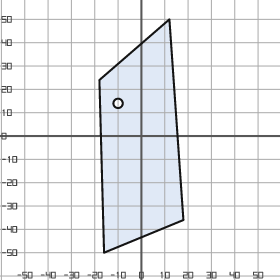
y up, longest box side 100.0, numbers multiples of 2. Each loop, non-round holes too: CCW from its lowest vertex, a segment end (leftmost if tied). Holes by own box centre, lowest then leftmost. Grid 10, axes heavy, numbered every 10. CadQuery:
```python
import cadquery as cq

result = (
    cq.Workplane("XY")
    .moveTo(-16.0, -50.0)
    .lineTo(18.0, -36.0)
    .lineTo(12.0, 50.0)
    .lineTo(-18.0, 24.0)
    .close()
    .moveTo(-10.0, 14.0)
    .circle(2.0)
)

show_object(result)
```